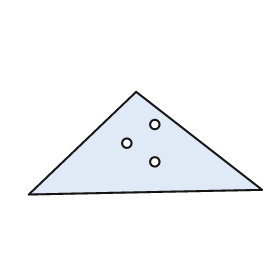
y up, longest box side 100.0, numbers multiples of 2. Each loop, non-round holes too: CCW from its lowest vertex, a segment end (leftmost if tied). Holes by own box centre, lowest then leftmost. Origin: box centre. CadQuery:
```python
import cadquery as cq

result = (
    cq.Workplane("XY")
    .moveTo(-50.0, -22.0)
    .lineTo(50.0, -20.0)
    .lineTo(-4.0, 22.0)
    .close()
    .moveTo(4.0, -8.0)
    .circle(2.0)
    .moveTo(-8.0, 0.0)
    .circle(2.0)
    .moveTo(4.0, 8.0)
    .circle(2.0)
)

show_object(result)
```